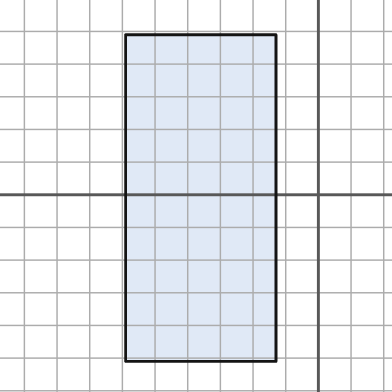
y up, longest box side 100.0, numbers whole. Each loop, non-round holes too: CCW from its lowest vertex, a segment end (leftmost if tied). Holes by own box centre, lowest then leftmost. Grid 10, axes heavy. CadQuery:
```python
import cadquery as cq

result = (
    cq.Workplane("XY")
    .moveTo(-59.0, -51.0)
    .lineTo(-13.0, -51.0)
    .lineTo(-13.0, 49.0)
    .lineTo(-59.0, 49.0)
    .close()
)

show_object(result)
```